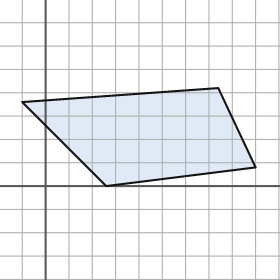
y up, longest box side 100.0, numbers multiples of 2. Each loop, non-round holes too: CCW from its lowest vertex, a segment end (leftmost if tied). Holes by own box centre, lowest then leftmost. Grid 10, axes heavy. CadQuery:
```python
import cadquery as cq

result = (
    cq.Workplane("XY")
    .moveTo(26.0, 0.0)
    .lineTo(90.0, 8.0)
    .lineTo(74.0, 42.0)
    .lineTo(-10.0, 36.0)
    .close()
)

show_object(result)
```